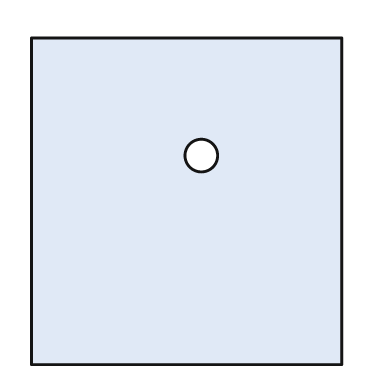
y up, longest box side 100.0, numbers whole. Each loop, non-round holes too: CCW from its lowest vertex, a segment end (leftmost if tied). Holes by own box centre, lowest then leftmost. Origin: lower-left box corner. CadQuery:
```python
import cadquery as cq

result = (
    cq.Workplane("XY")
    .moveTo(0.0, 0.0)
    .lineTo(95.0, 0.0)
    .lineTo(95.0, 100.0)
    .lineTo(0.0, 100.0)
    .close()
    .moveTo(52.0, 64.0)
    .circle(5.0)
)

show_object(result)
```